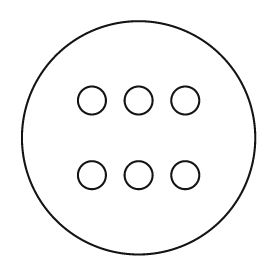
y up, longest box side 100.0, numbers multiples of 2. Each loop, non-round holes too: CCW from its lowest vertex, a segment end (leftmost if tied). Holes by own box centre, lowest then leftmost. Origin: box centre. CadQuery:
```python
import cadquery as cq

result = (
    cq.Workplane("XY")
    .moveTo(0.0, 0.0)
    .circle(50.0)
    .moveTo(-20.0, -16.0)
    .circle(6.0)
    .moveTo(0.0, -16.0)
    .circle(6.0)
    .moveTo(20.0, -16.0)
    .circle(6.0)
    .moveTo(-20.0, 16.0)
    .circle(6.0)
    .moveTo(0.0, 16.0)
    .circle(6.0)
    .moveTo(20.0, 16.0)
    .circle(6.0)
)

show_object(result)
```